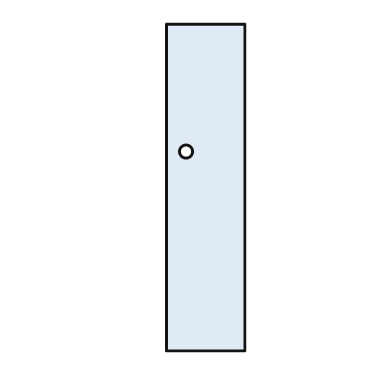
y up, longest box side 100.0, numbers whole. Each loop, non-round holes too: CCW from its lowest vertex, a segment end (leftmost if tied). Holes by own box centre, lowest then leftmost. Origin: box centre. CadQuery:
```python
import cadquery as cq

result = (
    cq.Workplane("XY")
    .moveTo(-12.0, -50.0)
    .lineTo(12.0, -50.0)
    .lineTo(12.0, 50.0)
    .lineTo(-12.0, 50.0)
    .close()
    .moveTo(-6.0, 11.0)
    .circle(2.0)
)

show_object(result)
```